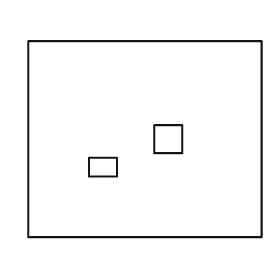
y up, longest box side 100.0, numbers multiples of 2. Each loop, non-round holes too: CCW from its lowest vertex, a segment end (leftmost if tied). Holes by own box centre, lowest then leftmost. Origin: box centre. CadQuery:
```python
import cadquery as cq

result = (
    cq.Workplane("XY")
    .moveTo(-50.0, -42.0)
    .lineTo(50.0, -42.0)
    .lineTo(50.0, 42.0)
    .lineTo(-50.0, 42.0)
    .close()
    .moveTo(-24.0, -16.0)
    .lineTo(-12.0, -16.0)
    .lineTo(-12.0, -8.0)
    .lineTo(-24.0, -8.0)
    .close()
    .moveTo(4.0, -6.0)
    .lineTo(16.0, -6.0)
    .lineTo(16.0, 6.0)
    .lineTo(4.0, 6.0)
    .close()
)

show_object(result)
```